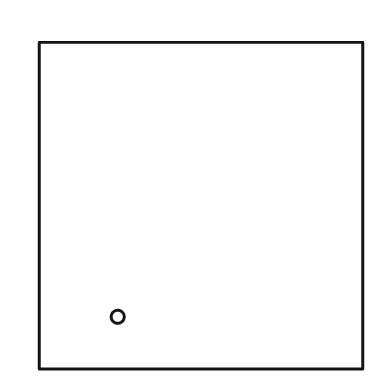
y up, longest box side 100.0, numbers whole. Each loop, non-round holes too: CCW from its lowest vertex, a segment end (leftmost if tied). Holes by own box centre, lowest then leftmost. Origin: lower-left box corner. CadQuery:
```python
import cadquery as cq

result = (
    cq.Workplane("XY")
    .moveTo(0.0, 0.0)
    .lineTo(99.0, 0.0)
    .lineTo(99.0, 100.0)
    .lineTo(0.0, 100.0)
    .close()
    .moveTo(24.0, 16.0)
    .circle(2.0)
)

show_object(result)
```